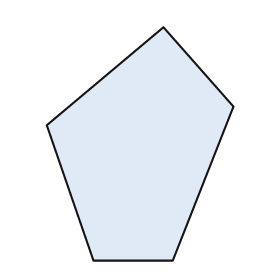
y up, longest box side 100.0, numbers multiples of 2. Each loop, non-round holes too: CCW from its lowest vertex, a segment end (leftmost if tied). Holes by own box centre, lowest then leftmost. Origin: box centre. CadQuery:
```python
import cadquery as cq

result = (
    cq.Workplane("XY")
    .moveTo(-20.0, -50.0)
    .lineTo(14.0, -50.0)
    .lineTo(40.0, 16.0)
    .lineTo(10.0, 50.0)
    .lineTo(-40.0, 8.0)
    .close()
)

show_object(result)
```